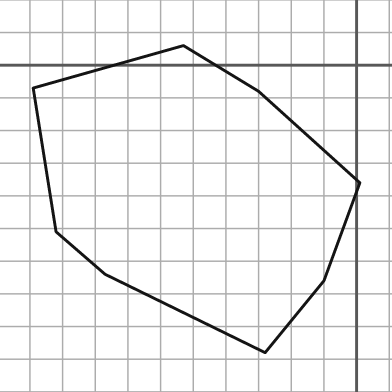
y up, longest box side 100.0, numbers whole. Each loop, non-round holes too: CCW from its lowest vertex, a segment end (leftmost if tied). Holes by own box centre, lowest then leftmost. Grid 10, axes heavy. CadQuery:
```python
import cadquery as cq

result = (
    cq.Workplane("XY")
    .moveTo(-28.0, -88.0)
    .lineTo(-10.0, -66.0)
    .lineTo(1.0, -36.0)
    .lineTo(-30.0, -8.0)
    .lineTo(-53.0, 6.0)
    .lineTo(-99.0, -7.0)
    .lineTo(-92.0, -51.0)
    .lineTo(-77.0, -64.0)
    .close()
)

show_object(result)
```